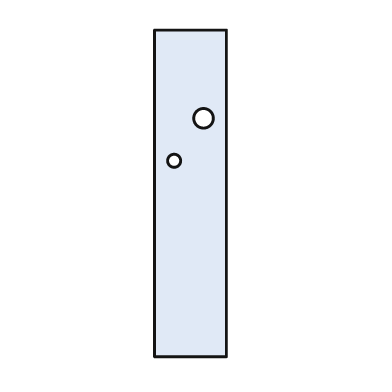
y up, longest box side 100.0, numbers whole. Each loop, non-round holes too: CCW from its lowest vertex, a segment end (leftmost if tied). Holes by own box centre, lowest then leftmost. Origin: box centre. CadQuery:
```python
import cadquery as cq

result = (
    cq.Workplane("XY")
    .moveTo(-11.0, -50.0)
    .lineTo(11.0, -50.0)
    .lineTo(11.0, 50.0)
    .lineTo(-11.0, 50.0)
    .close()
    .moveTo(-5.0, 10.0)
    .circle(2.0)
    .moveTo(4.0, 23.0)
    .circle(3.0)
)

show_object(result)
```